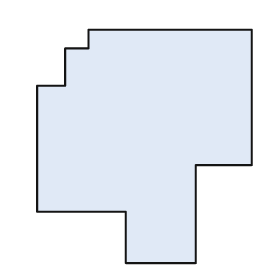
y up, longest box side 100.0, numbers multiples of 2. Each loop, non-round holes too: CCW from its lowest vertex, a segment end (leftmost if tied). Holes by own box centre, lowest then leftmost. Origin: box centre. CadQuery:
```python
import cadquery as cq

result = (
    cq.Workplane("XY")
    .moveTo(-8.0, -50.0)
    .lineTo(22.0, -50.0)
    .lineTo(22.0, -8.0)
    .lineTo(46.0, -8.0)
    .lineTo(46.0, 50.0)
    .lineTo(-24.0, 50.0)
    .lineTo(-24.0, 42.0)
    .lineTo(-34.0, 42.0)
    .lineTo(-34.0, 26.0)
    .lineTo(-46.0, 26.0)
    .lineTo(-46.0, -28.0)
    .lineTo(-8.0, -28.0)
    .close()
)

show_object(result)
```